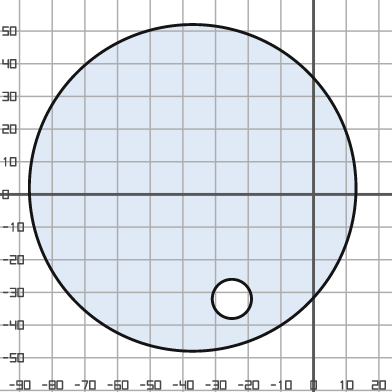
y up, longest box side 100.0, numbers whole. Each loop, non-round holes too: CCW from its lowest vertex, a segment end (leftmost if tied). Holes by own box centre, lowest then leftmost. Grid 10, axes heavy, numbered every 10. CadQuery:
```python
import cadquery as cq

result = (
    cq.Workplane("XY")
    .moveTo(-37.0, 2.0)
    .circle(50.0)
    .moveTo(-25.0, -32.0)
    .circle(6.0)
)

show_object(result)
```